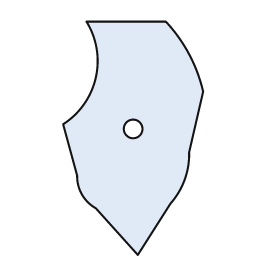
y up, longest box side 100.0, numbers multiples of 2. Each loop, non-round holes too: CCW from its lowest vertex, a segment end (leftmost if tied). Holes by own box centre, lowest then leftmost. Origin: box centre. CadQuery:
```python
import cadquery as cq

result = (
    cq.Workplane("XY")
    .moveTo(2.0, -50.0)
    .lineTo(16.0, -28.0)
    .threePointArc((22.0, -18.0), (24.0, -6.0))
    .lineTo(30.0, 20.0)
    .threePointArc((24.0, 36.0), (14.0, 50.0))
    .lineTo(-20.0, 50.0)
    .threePointArc((-16.0, 26.0), (-30.0, 6.0))
    .lineTo(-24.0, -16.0)
    .threePointArc((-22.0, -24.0), (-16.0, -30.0))
    .close()
    .moveTo(0.0, 4.0)
    .circle(4.0)
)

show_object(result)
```